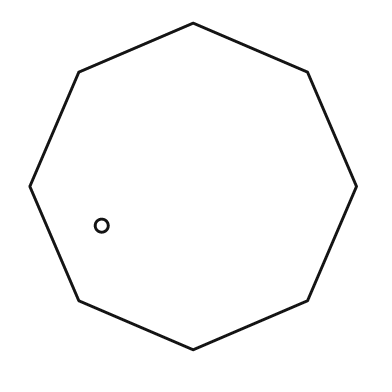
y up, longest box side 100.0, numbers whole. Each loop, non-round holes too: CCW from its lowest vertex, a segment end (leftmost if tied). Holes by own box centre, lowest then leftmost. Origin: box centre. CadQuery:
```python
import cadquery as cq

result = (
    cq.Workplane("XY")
    .moveTo(0.0, -50.0)
    .lineTo(35.0, -35.0)
    .lineTo(50.0, 0.0)
    .lineTo(35.0, 35.0)
    .lineTo(0.0, 50.0)
    .lineTo(-35.0, 35.0)
    .lineTo(-50.0, 0.0)
    .lineTo(-35.0, -35.0)
    .close()
    .moveTo(-28.0, -12.0)
    .circle(2.0)
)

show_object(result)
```